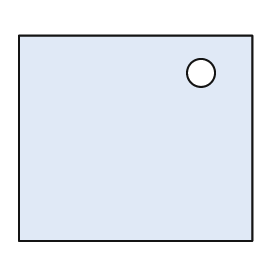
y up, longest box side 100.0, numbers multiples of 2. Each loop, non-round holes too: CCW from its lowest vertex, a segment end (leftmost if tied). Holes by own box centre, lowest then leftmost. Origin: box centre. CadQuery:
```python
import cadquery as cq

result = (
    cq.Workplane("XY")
    .moveTo(-50.0, -44.0)
    .lineTo(50.0, -44.0)
    .lineTo(50.0, 44.0)
    .lineTo(-50.0, 44.0)
    .close()
    .moveTo(28.0, 28.0)
    .circle(6.0)
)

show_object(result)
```